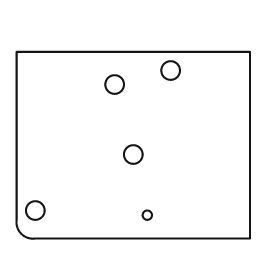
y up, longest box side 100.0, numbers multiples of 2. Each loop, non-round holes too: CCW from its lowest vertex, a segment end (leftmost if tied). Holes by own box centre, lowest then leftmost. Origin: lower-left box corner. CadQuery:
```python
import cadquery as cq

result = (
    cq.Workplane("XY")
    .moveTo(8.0, 0.0)
    .lineTo(100.0, 0.0)
    .lineTo(100.0, 80.0)
    .lineTo(0.0, 80.0)
    .lineTo(0.0, 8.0)
    .threePointArc((2.0, 2.0), (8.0, 0.0))
    .close()
    .moveTo(56.0, 10.0)
    .circle(2.0)
    .moveTo(8.0, 12.0)
    .circle(4.0)
    .moveTo(50.0, 36.0)
    .circle(4.0)
    .moveTo(42.0, 66.0)
    .circle(4.0)
    .moveTo(66.0, 72.0)
    .circle(4.0)
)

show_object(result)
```